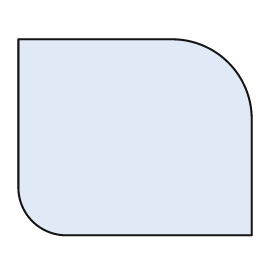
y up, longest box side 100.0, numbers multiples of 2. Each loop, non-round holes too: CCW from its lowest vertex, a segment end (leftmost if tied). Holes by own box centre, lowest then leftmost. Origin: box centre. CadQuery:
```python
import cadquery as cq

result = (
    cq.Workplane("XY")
    .moveTo(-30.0, -42.0)
    .lineTo(50.0, -42.0)
    .lineTo(50.0, 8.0)
    .threePointArc((40.0, 32.0), (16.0, 42.0))
    .lineTo(-50.0, 42.0)
    .lineTo(-50.0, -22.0)
    .threePointArc((-44.0, -36.0), (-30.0, -42.0))
    .close()
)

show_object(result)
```